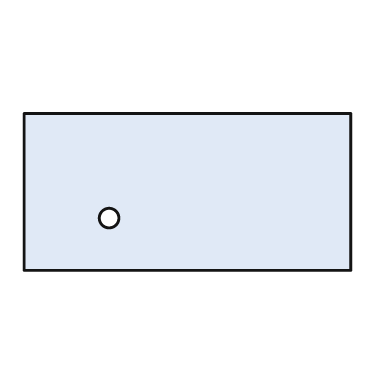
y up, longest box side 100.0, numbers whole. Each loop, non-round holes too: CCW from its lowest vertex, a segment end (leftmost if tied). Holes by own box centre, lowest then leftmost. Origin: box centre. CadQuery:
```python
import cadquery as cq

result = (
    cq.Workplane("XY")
    .moveTo(-50.0, -24.0)
    .lineTo(50.0, -24.0)
    .lineTo(50.0, 24.0)
    .lineTo(-50.0, 24.0)
    .close()
    .moveTo(-24.0, -8.0)
    .circle(3.0)
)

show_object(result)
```